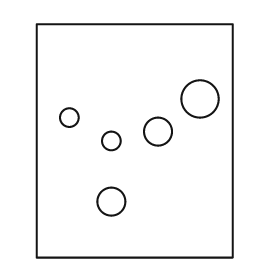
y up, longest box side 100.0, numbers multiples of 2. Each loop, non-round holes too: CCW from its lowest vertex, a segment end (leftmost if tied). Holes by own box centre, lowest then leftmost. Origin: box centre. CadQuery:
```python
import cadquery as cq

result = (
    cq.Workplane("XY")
    .moveTo(-42.0, -50.0)
    .lineTo(42.0, -50.0)
    .lineTo(42.0, 50.0)
    .lineTo(-42.0, 50.0)
    .close()
    .moveTo(-10.0, -26.0)
    .circle(6.0)
    .moveTo(-10.0, 0.0)
    .circle(4.0)
    .moveTo(10.0, 4.0)
    .circle(6.0)
    .moveTo(-28.0, 10.0)
    .circle(4.0)
    .moveTo(28.0, 18.0)
    .circle(8.0)
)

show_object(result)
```